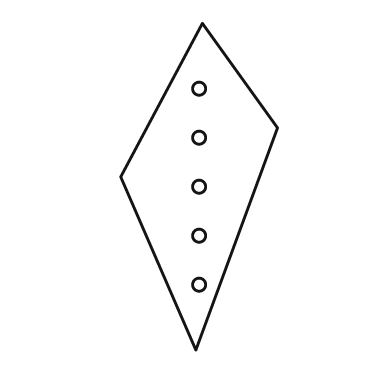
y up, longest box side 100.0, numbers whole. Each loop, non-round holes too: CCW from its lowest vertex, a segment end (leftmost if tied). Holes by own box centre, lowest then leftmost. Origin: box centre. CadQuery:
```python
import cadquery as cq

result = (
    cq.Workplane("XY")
    .moveTo(-1.0, -50.0)
    .lineTo(24.0, 18.0)
    .lineTo(1.0, 50.0)
    .lineTo(-24.0, 3.0)
    .close()
    .moveTo(0.0, -30.0)
    .circle(2.0)
    .moveTo(0.0, -15.0)
    .circle(2.0)
    .moveTo(0.0, 0.0)
    .circle(2.0)
    .moveTo(0.0, 15.0)
    .circle(2.0)
    .moveTo(0.0, 30.0)
    .circle(2.0)
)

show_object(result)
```